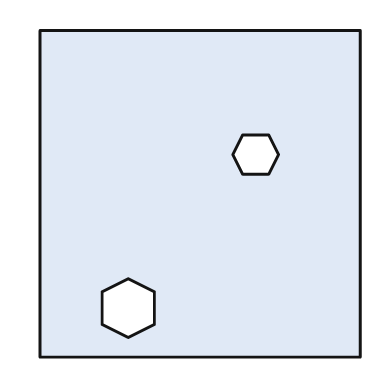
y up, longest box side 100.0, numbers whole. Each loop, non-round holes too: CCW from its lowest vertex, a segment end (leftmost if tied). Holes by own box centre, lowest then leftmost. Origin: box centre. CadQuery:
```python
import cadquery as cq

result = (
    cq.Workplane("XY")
    .moveTo(-49.0, -50.0)
    .lineTo(49.0, -50.0)
    .lineTo(49.0, 50.0)
    .lineTo(-49.0, 50.0)
    .close()
    .moveTo(-22.0, -44.0)
    .lineTo(-14.0, -40.0)
    .lineTo(-14.0, -30.0)
    .lineTo(-22.0, -26.0)
    .lineTo(-30.0, -30.0)
    .lineTo(-30.0, -40.0)
    .close()
    .moveTo(13.0, 6.0)
    .lineTo(21.0, 6.0)
    .lineTo(24.0, 12.0)
    .lineTo(21.0, 18.0)
    .lineTo(13.0, 18.0)
    .lineTo(10.0, 12.0)
    .close()
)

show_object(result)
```